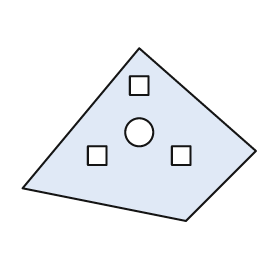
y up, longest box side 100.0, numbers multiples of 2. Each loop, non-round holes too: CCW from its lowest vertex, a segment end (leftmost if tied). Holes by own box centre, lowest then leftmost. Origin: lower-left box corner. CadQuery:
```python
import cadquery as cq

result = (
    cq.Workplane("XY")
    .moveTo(70.0, 0.0)
    .lineTo(100.0, 30.0)
    .lineTo(50.0, 74.0)
    .lineTo(0.0, 14.0)
    .close()
    .moveTo(28.0, 24.0)
    .lineTo(36.0, 24.0)
    .lineTo(36.0, 32.0)
    .lineTo(28.0, 32.0)
    .close()
    .moveTo(64.0, 24.0)
    .lineTo(72.0, 24.0)
    .lineTo(72.0, 32.0)
    .lineTo(64.0, 32.0)
    .close()
    .moveTo(50.0, 38.0)
    .circle(6.0)
    .moveTo(46.0, 54.0)
    .lineTo(54.0, 54.0)
    .lineTo(54.0, 62.0)
    .lineTo(46.0, 62.0)
    .close()
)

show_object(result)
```